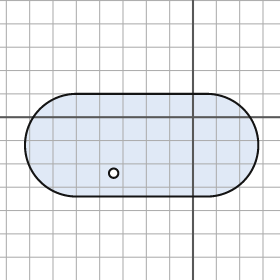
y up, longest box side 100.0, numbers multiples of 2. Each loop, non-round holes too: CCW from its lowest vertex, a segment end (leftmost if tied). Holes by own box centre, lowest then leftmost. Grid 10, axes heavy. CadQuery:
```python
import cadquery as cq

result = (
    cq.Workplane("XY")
    .moveTo(-50.0, -34.0)
    .lineTo(6.0, -34.0)
    .threePointArc((28.0, -12.0), (6.0, 10.0))
    .lineTo(-50.0, 10.0)
    .threePointArc((-72.0, -12.0), (-50.0, -34.0))
    .close()
    .moveTo(-34.0, -24.0)
    .circle(2.0)
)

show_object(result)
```